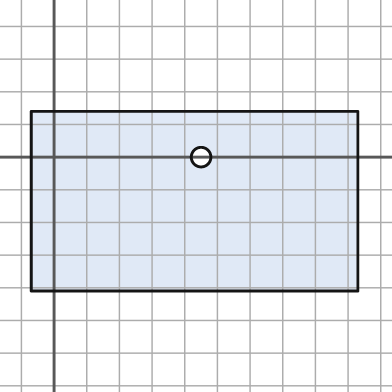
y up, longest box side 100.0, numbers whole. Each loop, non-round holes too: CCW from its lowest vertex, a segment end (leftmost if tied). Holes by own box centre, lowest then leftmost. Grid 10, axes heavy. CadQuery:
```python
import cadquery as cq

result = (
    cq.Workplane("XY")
    .moveTo(-7.0, -41.0)
    .lineTo(93.0, -41.0)
    .lineTo(93.0, 14.0)
    .lineTo(-7.0, 14.0)
    .close()
    .moveTo(45.0, 0.0)
    .circle(3.0)
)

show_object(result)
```